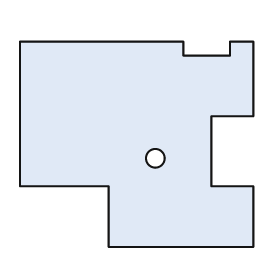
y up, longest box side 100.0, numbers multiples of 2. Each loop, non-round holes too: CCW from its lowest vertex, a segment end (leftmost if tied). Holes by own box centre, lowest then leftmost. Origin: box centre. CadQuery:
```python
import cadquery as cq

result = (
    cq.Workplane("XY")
    .moveTo(-12.0, -44.0)
    .lineTo(50.0, -44.0)
    .lineTo(50.0, -18.0)
    .lineTo(32.0, -18.0)
    .lineTo(32.0, 12.0)
    .lineTo(50.0, 12.0)
    .lineTo(50.0, 44.0)
    .lineTo(40.0, 44.0)
    .lineTo(40.0, 38.0)
    .lineTo(20.0, 38.0)
    .lineTo(20.0, 44.0)
    .lineTo(-50.0, 44.0)
    .lineTo(-50.0, -18.0)
    .lineTo(-12.0, -18.0)
    .close()
    .moveTo(8.0, -6.0)
    .circle(4.0)
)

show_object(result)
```